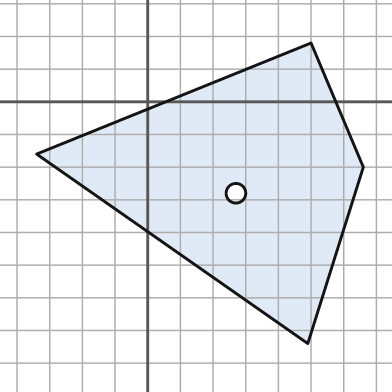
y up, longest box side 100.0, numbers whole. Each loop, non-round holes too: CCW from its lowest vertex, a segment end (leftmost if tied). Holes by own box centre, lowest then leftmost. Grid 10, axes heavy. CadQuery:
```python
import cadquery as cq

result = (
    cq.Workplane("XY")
    .moveTo(49.0, -74.0)
    .lineTo(66.0, -20.0)
    .lineTo(50.0, 18.0)
    .lineTo(-34.0, -16.0)
    .close()
    .moveTo(27.0, -28.0)
    .circle(3.0)
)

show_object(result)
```